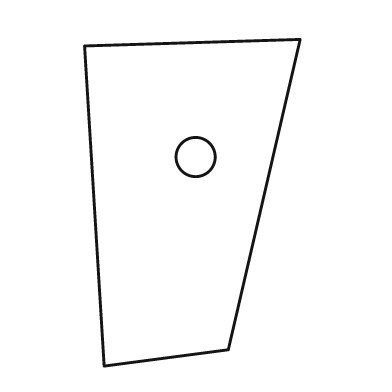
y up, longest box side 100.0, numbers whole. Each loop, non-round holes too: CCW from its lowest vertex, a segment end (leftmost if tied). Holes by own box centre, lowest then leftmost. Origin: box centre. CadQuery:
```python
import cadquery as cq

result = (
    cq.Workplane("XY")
    .moveTo(-27.0, -50.0)
    .lineTo(11.0, -45.0)
    .lineTo(33.0, 50.0)
    .lineTo(-33.0, 48.0)
    .close()
    .moveTo(1.0, 14.0)
    .circle(6.0)
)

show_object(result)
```